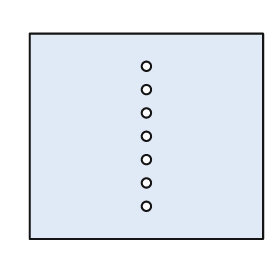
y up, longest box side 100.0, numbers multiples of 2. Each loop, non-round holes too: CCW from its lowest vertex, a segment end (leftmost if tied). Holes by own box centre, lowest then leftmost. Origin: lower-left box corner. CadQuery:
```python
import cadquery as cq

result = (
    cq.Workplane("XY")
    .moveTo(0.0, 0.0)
    .lineTo(100.0, 0.0)
    .lineTo(100.0, 88.0)
    .lineTo(0.0, 88.0)
    .close()
    .moveTo(50.0, 14.0)
    .circle(2.0)
    .moveTo(50.0, 24.0)
    .circle(2.0)
    .moveTo(50.0, 34.0)
    .circle(2.0)
    .moveTo(50.0, 44.0)
    .circle(2.0)
    .moveTo(50.0, 54.0)
    .circle(2.0)
    .moveTo(50.0, 64.0)
    .circle(2.0)
    .moveTo(50.0, 74.0)
    .circle(2.0)
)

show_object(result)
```